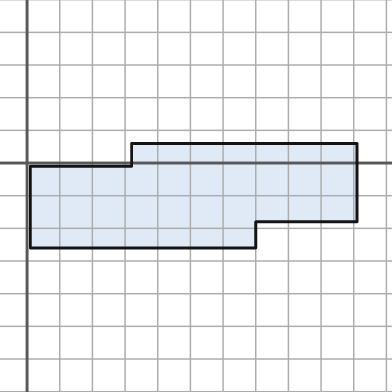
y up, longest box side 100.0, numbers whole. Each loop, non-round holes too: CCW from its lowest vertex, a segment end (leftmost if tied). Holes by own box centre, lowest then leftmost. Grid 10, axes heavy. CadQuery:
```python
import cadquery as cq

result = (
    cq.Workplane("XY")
    .moveTo(1.0, -26.0)
    .lineTo(70.0, -26.0)
    .lineTo(70.0, -18.0)
    .lineTo(101.0, -18.0)
    .lineTo(101.0, 6.0)
    .lineTo(32.0, 6.0)
    .lineTo(32.0, -1.0)
    .lineTo(1.0, -1.0)
    .close()
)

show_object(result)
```